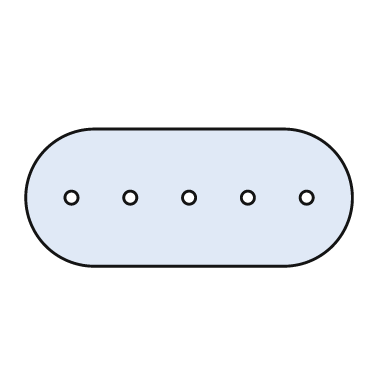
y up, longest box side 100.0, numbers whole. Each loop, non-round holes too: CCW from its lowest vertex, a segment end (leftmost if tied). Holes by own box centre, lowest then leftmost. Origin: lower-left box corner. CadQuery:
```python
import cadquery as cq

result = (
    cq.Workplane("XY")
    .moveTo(21.0, 0.0)
    .lineTo(79.0, 0.0)
    .threePointArc((100.0, 21.0), (79.0, 42.0))
    .lineTo(21.0, 42.0)
    .threePointArc((0.0, 21.0), (21.0, 0.0))
    .close()
    .moveTo(14.0, 21.0)
    .circle(2.0)
    .moveTo(32.0, 21.0)
    .circle(2.0)
    .moveTo(50.0, 21.0)
    .circle(2.0)
    .moveTo(68.0, 21.0)
    .circle(2.0)
    .moveTo(86.0, 21.0)
    .circle(2.0)
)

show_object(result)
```